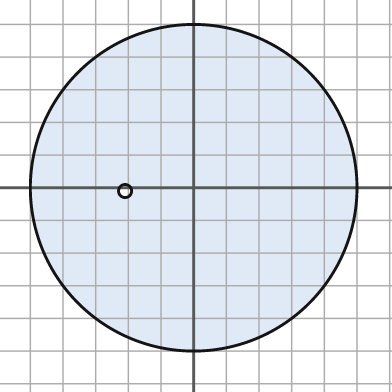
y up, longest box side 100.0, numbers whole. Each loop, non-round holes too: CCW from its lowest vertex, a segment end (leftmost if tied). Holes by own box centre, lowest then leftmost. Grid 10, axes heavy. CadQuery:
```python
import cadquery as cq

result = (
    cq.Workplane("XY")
    .moveTo(0.0, 0.0)
    .circle(50.0)
    .moveTo(-21.0, -1.0)
    .circle(2.0)
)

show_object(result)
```